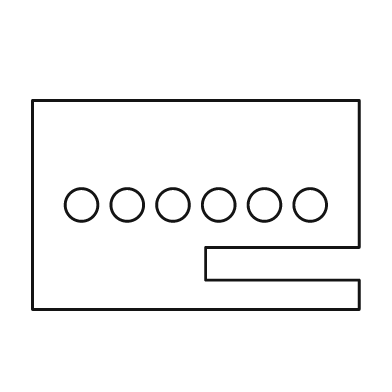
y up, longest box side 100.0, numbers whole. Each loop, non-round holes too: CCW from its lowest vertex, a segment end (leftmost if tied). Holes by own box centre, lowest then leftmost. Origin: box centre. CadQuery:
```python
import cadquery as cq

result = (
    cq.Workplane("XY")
    .moveTo(-50.0, -32.0)
    .lineTo(50.0, -32.0)
    .lineTo(50.0, -23.0)
    .lineTo(3.0, -23.0)
    .lineTo(3.0, -13.0)
    .lineTo(50.0, -13.0)
    .lineTo(50.0, 32.0)
    .lineTo(-50.0, 32.0)
    .close()
    .moveTo(-35.0, 0.0)
    .circle(5.0)
    .moveTo(-21.0, 0.0)
    .circle(5.0)
    .moveTo(-7.0, 0.0)
    .circle(5.0)
    .moveTo(7.0, 0.0)
    .circle(5.0)
    .moveTo(21.0, 0.0)
    .circle(5.0)
    .moveTo(35.0, 0.0)
    .circle(5.0)
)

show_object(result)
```